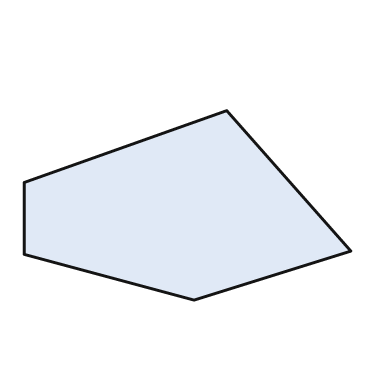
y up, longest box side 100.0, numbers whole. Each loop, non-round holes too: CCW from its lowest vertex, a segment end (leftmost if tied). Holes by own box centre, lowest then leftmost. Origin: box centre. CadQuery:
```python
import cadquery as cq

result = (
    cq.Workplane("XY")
    .moveTo(2.0, -29.0)
    .lineTo(50.0, -14.0)
    .lineTo(12.0, 29.0)
    .lineTo(-50.0, 7.0)
    .lineTo(-50.0, -15.0)
    .close()
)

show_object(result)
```